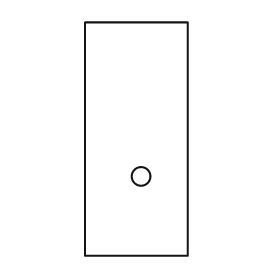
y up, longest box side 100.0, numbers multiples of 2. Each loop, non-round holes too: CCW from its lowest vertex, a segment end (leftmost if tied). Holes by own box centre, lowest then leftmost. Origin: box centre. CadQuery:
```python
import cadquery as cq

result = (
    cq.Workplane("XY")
    .moveTo(-22.0, -50.0)
    .lineTo(22.0, -50.0)
    .lineTo(22.0, 50.0)
    .lineTo(-22.0, 50.0)
    .close()
    .moveTo(2.0, -16.0)
    .circle(4.0)
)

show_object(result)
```